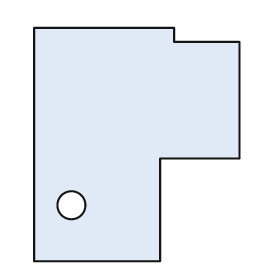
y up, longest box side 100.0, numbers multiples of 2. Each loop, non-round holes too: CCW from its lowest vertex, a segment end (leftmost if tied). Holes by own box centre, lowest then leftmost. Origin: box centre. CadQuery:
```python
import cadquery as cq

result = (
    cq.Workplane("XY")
    .moveTo(-44.0, -50.0)
    .lineTo(10.0, -50.0)
    .lineTo(10.0, -6.0)
    .lineTo(44.0, -6.0)
    .lineTo(44.0, 44.0)
    .lineTo(16.0, 44.0)
    .lineTo(16.0, 50.0)
    .lineTo(-44.0, 50.0)
    .close()
    .moveTo(-28.0, -26.0)
    .circle(6.0)
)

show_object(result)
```